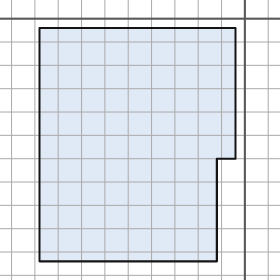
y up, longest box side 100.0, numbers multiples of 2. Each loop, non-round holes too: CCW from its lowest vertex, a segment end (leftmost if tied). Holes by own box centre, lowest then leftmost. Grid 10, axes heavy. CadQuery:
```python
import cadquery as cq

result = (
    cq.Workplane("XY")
    .moveTo(-88.0, -104.0)
    .lineTo(-12.0, -104.0)
    .lineTo(-12.0, -60.0)
    .lineTo(-4.0, -60.0)
    .lineTo(-4.0, -4.0)
    .lineTo(-88.0, -4.0)
    .close()
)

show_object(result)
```